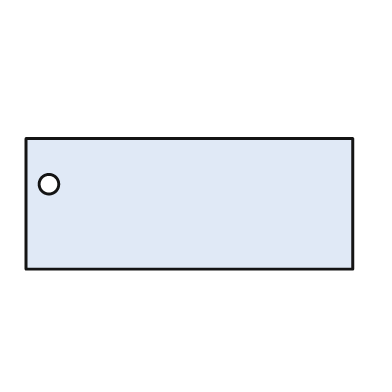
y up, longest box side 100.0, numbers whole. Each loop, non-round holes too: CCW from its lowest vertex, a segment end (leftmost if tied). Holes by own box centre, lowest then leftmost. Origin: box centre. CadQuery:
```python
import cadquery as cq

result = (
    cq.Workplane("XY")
    .moveTo(-50.0, -20.0)
    .lineTo(50.0, -20.0)
    .lineTo(50.0, 20.0)
    .lineTo(-50.0, 20.0)
    .close()
    .moveTo(-43.0, 6.0)
    .circle(3.0)
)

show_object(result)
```